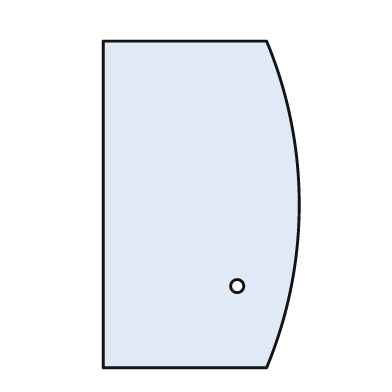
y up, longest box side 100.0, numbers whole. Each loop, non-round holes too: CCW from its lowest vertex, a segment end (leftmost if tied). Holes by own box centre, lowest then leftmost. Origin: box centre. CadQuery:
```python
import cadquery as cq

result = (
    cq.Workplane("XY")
    .moveTo(-30.0, -50.0)
    .lineTo(20.0, -50.0)
    .threePointArc((30.0, 0.0), (20.0, 50.0))
    .lineTo(-30.0, 50.0)
    .close()
    .moveTo(11.0, -25.0)
    .circle(2.0)
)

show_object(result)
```